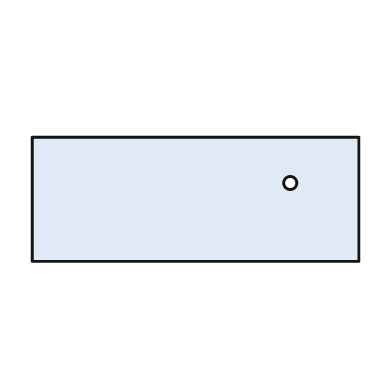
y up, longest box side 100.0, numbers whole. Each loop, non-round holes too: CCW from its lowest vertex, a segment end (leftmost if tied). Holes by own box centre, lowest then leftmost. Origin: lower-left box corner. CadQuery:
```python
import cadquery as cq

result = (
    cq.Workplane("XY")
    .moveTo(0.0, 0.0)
    .lineTo(100.0, 0.0)
    .lineTo(100.0, 38.0)
    .lineTo(0.0, 38.0)
    .close()
    .moveTo(79.0, 24.0)
    .circle(2.0)
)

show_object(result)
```